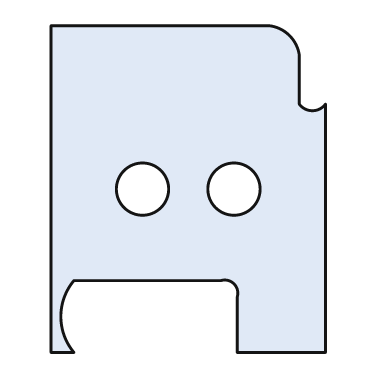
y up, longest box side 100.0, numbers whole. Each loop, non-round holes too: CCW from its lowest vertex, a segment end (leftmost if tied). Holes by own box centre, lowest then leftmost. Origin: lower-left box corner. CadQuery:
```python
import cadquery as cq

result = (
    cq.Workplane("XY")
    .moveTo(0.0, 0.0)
    .lineTo(7.0, 0.0)
    .threePointArc((3.0, 11.0), (7.0, 22.0))
    .lineTo(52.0, 22.0)
    .threePointArc((56.0, 21.0), (57.0, 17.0))
    .lineTo(57.0, 0.0)
    .lineTo(84.0, 0.0)
    .lineTo(84.0, 76.0)
    .threePointArc((80.0, 74.0), (76.0, 76.0))
    .lineTo(76.0, 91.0)
    .threePointArc((73.0, 97.0), (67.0, 100.0))
    .lineTo(0.0, 100.0)
    .close()
    .moveTo(28.0, 50.0)
    .circle(8.0)
    .moveTo(56.0, 50.0)
    .circle(8.0)
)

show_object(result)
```